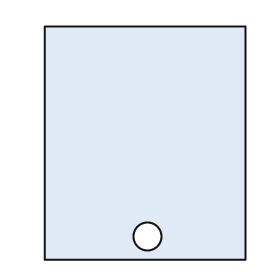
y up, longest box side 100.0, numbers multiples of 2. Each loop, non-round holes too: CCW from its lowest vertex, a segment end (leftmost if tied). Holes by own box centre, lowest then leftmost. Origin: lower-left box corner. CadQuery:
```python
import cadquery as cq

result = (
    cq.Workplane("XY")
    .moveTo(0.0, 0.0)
    .lineTo(86.0, 0.0)
    .lineTo(86.0, 100.0)
    .lineTo(0.0, 100.0)
    .close()
    .moveTo(44.0, 10.0)
    .circle(6.0)
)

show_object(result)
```